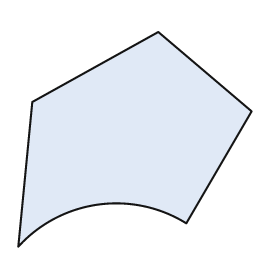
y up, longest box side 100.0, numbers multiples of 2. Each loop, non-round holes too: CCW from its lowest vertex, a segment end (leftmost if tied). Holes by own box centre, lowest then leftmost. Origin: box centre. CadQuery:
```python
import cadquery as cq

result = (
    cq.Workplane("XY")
    .moveTo(-50.0, -46.0)
    .threePointArc((-16.0, -28.0), (22.0, -36.0))
    .lineTo(50.0, 12.0)
    .lineTo(10.0, 46.0)
    .lineTo(-44.0, 16.0)
    .close()
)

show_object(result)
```